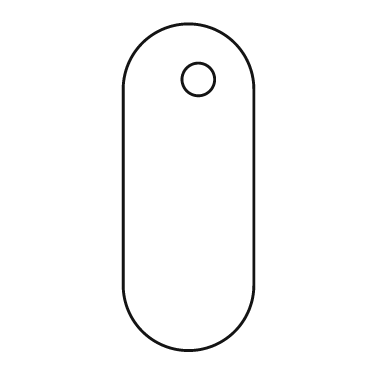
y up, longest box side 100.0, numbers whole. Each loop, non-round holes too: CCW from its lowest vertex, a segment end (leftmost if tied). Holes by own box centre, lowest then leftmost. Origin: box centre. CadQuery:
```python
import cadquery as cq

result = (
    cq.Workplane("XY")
    .moveTo(-20.0, -30.0)
    .threePointArc((0.0, -50.0), (20.0, -30.0))
    .lineTo(20.0, 30.0)
    .threePointArc((0.0, 50.0), (-20.0, 30.0))
    .close()
    .moveTo(3.0, 33.0)
    .circle(5.0)
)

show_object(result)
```